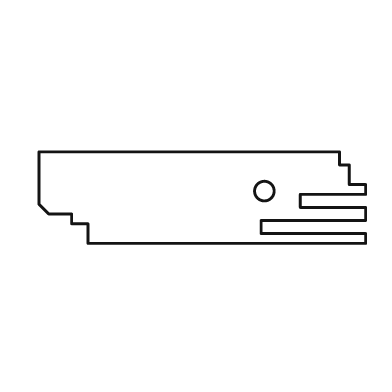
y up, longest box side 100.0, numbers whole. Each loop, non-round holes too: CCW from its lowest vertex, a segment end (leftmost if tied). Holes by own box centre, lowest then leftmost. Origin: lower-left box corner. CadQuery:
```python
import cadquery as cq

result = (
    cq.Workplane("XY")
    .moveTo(15.0, 0.0)
    .lineTo(100.0, 0.0)
    .lineTo(100.0, 3.0)
    .lineTo(68.0, 3.0)
    .lineTo(68.0, 7.0)
    .lineTo(100.0, 7.0)
    .lineTo(100.0, 11.0)
    .lineTo(80.0, 11.0)
    .lineTo(80.0, 15.0)
    .lineTo(100.0, 15.0)
    .lineTo(100.0, 18.0)
    .lineTo(95.0, 18.0)
    .lineTo(95.0, 24.0)
    .lineTo(92.0, 24.0)
    .lineTo(92.0, 28.0)
    .lineTo(0.0, 28.0)
    .lineTo(0.0, 12.0)
    .lineTo(3.0, 9.0)
    .lineTo(10.0, 9.0)
    .lineTo(10.0, 6.0)
    .lineTo(15.0, 6.0)
    .close()
    .moveTo(69.0, 16.0)
    .circle(3.0)
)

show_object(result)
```